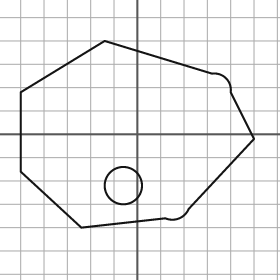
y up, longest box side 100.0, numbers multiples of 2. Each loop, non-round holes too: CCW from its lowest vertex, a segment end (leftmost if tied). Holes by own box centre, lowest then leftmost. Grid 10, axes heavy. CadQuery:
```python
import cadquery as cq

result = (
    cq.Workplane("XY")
    .moveTo(-24.0, -40.0)
    .lineTo(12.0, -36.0)
    .threePointArc((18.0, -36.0), (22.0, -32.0))
    .lineTo(50.0, -2.0)
    .lineTo(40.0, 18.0)
    .threePointArc((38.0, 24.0), (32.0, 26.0))
    .lineTo(-14.0, 40.0)
    .lineTo(-50.0, 18.0)
    .lineTo(-50.0, -16.0)
    .close()
    .moveTo(-6.0, -22.0)
    .circle(8.0)
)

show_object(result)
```